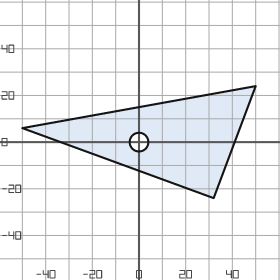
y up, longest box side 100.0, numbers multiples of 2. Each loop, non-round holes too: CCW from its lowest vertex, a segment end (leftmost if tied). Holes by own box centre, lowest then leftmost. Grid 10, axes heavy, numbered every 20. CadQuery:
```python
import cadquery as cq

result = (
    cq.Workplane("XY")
    .moveTo(32.0, -24.0)
    .lineTo(50.0, 24.0)
    .lineTo(-50.0, 6.0)
    .close()
    .moveTo(0.0, 0.0)
    .circle(4.0)
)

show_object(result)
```